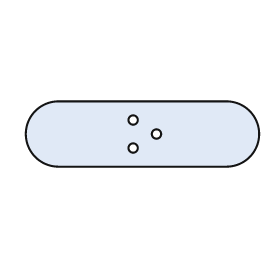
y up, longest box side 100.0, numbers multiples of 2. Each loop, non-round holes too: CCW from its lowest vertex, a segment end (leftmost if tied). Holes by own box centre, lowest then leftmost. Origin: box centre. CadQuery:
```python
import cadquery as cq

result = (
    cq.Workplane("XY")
    .moveTo(-36.0, -14.0)
    .lineTo(36.0, -14.0)
    .threePointArc((50.0, 0.0), (36.0, 14.0))
    .lineTo(-36.0, 14.0)
    .threePointArc((-50.0, 0.0), (-36.0, -14.0))
    .close()
    .moveTo(-4.0, -6.0)
    .circle(2.0)
    .moveTo(6.0, 0.0)
    .circle(2.0)
    .moveTo(-4.0, 6.0)
    .circle(2.0)
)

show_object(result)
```